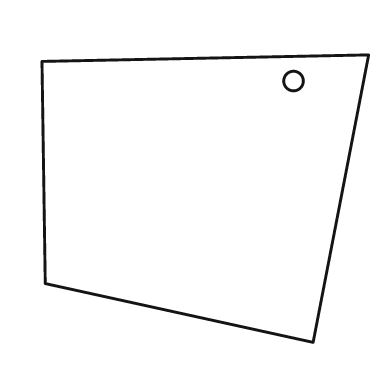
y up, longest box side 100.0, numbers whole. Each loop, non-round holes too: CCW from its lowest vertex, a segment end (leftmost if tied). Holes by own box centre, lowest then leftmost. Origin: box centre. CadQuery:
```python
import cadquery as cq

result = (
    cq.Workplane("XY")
    .moveTo(33.0, -44.0)
    .lineTo(50.0, 44.0)
    .lineTo(-50.0, 42.0)
    .lineTo(-49.0, -26.0)
    .close()
    .moveTo(27.0, 36.0)
    .circle(3.0)
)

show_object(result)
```